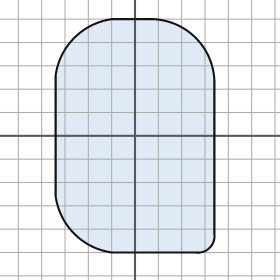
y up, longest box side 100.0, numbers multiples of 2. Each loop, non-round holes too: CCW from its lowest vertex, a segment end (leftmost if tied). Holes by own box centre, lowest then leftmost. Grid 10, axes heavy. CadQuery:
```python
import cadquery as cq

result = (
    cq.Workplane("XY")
    .moveTo(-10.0, -50.0)
    .lineTo(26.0, -50.0)
    .threePointArc((32.0, -48.0), (34.0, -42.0))
    .lineTo(34.0, 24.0)
    .threePointArc((26.0, 42.0), (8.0, 50.0))
    .lineTo(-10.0, 50.0)
    .threePointArc((-26.0, 42.0), (-34.0, 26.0))
    .lineTo(-34.0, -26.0)
    .threePointArc((-26.0, -42.0), (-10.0, -50.0))
    .close()
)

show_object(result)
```